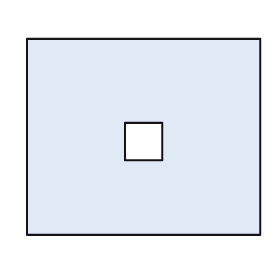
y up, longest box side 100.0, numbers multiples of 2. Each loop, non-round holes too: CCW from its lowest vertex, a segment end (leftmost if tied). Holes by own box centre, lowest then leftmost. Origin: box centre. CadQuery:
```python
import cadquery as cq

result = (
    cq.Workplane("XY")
    .moveTo(-50.0, -42.0)
    .lineTo(50.0, -42.0)
    .lineTo(50.0, 42.0)
    .lineTo(-50.0, 42.0)
    .close()
    .moveTo(-8.0, -10.0)
    .lineTo(8.0, -10.0)
    .lineTo(8.0, 6.0)
    .lineTo(-8.0, 6.0)
    .close()
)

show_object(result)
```